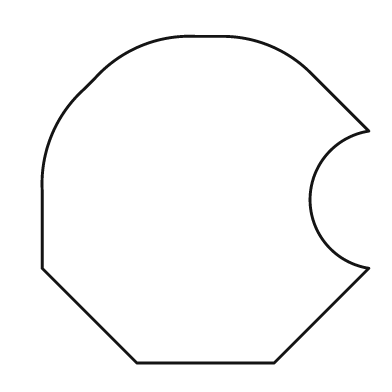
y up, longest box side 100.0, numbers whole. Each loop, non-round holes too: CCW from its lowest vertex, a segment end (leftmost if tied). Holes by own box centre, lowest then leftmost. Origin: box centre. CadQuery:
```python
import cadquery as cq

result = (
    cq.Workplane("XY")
    .moveTo(-21.0, -50.0)
    .lineTo(21.0, -50.0)
    .lineTo(50.0, -21.0)
    .threePointArc((32.0, 0.0), (50.0, 21.0))
    .lineTo(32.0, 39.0)
    .threePointArc((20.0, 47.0), (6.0, 50.0))
    .lineTo(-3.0, 50.0)
    .threePointArc((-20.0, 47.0), (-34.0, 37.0))
    .lineTo(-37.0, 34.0)
    .threePointArc((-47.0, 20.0), (-50.0, 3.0))
    .lineTo(-50.0, -21.0)
    .close()
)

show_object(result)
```